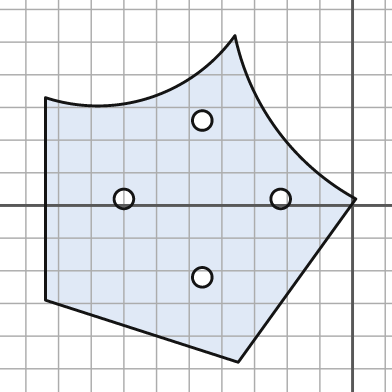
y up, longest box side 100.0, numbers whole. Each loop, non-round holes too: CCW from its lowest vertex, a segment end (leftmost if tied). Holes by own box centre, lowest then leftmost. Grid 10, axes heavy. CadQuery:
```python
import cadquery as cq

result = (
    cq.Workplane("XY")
    .moveTo(-35.0, -48.0)
    .lineTo(1.0, 2.0)
    .threePointArc((-23.0, 23.0), (-36.0, 52.0))
    .threePointArc((-62.0, 33.0), (-94.0, 33.0))
    .lineTo(-94.0, -29.0)
    .close()
    .moveTo(-46.0, -22.0)
    .circle(3.0)
    .moveTo(-70.0, 2.0)
    .circle(3.0)
    .moveTo(-22.0, 2.0)
    .circle(3.0)
    .moveTo(-46.0, 26.0)
    .circle(3.0)
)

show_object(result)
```